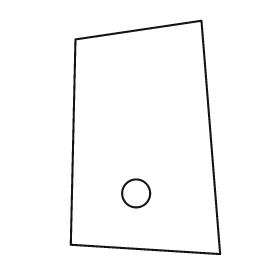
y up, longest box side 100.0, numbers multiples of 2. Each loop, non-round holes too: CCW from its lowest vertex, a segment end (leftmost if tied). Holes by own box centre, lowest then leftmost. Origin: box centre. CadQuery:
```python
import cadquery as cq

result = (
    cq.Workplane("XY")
    .moveTo(32.0, -50.0)
    .lineTo(24.0, 50.0)
    .lineTo(-30.0, 42.0)
    .lineTo(-32.0, -46.0)
    .close()
    .moveTo(-4.0, -24.0)
    .circle(6.0)
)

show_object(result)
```